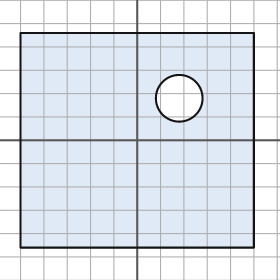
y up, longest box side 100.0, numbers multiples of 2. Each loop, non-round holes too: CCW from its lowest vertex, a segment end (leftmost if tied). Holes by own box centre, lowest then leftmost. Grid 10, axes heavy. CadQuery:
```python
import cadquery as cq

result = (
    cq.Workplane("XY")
    .moveTo(-50.0, -46.0)
    .lineTo(50.0, -46.0)
    .lineTo(50.0, 46.0)
    .lineTo(-50.0, 46.0)
    .close()
    .moveTo(18.0, 18.0)
    .circle(10.0)
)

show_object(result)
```